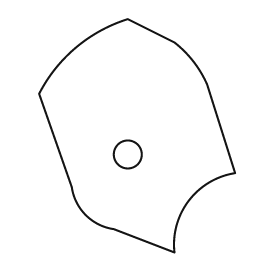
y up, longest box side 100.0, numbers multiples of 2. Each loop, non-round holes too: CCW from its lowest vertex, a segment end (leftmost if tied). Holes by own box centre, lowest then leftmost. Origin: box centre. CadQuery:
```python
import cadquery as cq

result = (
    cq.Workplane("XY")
    .moveTo(16.0, -50.0)
    .threePointArc((22.0, -28.0), (42.0, -16.0))
    .lineTo(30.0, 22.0)
    .threePointArc((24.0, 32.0), (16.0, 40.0))
    .lineTo(-4.0, 50.0)
    .threePointArc((-26.0, 38.0), (-42.0, 18.0))
    .lineTo(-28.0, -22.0)
    .threePointArc((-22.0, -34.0), (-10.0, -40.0))
    .close()
    .moveTo(-4.0, -8.0)
    .circle(6.0)
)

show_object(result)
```